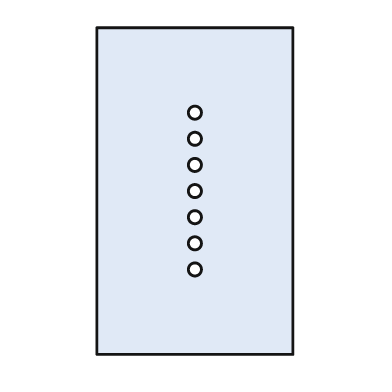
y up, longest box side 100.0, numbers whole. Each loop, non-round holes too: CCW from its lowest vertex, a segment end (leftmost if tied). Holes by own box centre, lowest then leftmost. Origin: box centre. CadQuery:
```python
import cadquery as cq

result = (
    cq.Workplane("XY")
    .moveTo(-30.0, -50.0)
    .lineTo(30.0, -50.0)
    .lineTo(30.0, 50.0)
    .lineTo(-30.0, 50.0)
    .close()
    .moveTo(0.0, -24.0)
    .circle(2.0)
    .moveTo(0.0, -16.0)
    .circle(2.0)
    .moveTo(0.0, -8.0)
    .circle(2.0)
    .moveTo(0.0, 0.0)
    .circle(2.0)
    .moveTo(0.0, 8.0)
    .circle(2.0)
    .moveTo(0.0, 16.0)
    .circle(2.0)
    .moveTo(0.0, 24.0)
    .circle(2.0)
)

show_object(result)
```